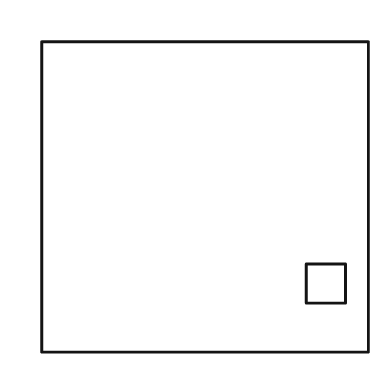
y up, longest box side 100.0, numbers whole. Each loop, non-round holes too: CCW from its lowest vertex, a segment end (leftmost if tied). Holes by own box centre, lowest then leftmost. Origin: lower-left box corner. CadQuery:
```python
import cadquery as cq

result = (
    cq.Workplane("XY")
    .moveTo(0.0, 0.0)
    .lineTo(100.0, 0.0)
    .lineTo(100.0, 95.0)
    .lineTo(0.0, 95.0)
    .close()
    .moveTo(81.0, 15.0)
    .lineTo(93.0, 15.0)
    .lineTo(93.0, 27.0)
    .lineTo(81.0, 27.0)
    .close()
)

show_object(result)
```